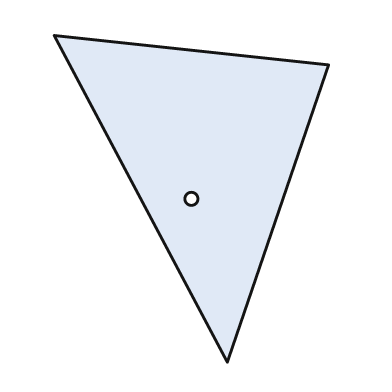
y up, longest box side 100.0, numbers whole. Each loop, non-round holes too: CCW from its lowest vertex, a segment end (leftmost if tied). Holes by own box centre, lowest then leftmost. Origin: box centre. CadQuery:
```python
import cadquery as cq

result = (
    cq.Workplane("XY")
    .moveTo(11.0, -50.0)
    .lineTo(42.0, 41.0)
    .lineTo(-42.0, 50.0)
    .close()
    .moveTo(0.0, 0.0)
    .circle(2.0)
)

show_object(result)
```